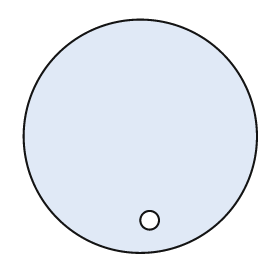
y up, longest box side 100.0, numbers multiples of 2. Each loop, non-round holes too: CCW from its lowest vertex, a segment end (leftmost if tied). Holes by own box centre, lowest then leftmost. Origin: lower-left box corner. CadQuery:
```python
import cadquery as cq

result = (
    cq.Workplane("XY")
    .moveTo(50.0, 50.0)
    .circle(50.0)
    .moveTo(54.0, 14.0)
    .circle(4.0)
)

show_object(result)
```